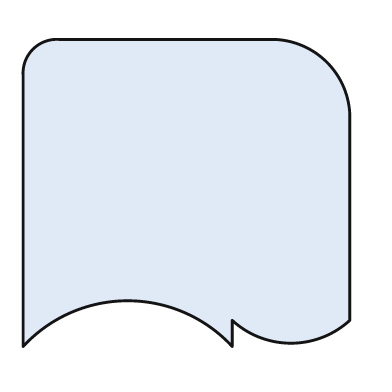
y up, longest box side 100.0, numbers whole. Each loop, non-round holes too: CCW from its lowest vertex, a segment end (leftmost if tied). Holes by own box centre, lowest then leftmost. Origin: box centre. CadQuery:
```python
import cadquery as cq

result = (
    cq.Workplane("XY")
    .moveTo(-50.0, -47.0)
    .threePointArc((-18.0, -33.0), (14.0, -47.0))
    .lineTo(14.0, -39.0)
    .threePointArc((32.0, -46.0), (50.0, -39.0))
    .lineTo(50.0, 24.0)
    .threePointArc((43.0, 40.0), (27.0, 47.0))
    .lineTo(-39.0, 47.0)
    .threePointArc((-47.0, 44.0), (-50.0, 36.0))
    .close()
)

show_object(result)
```